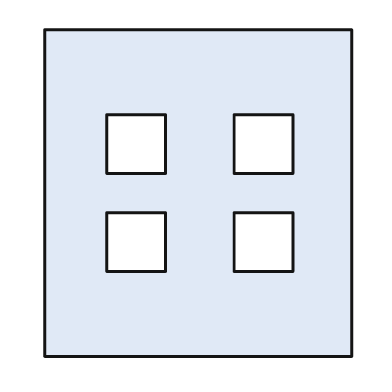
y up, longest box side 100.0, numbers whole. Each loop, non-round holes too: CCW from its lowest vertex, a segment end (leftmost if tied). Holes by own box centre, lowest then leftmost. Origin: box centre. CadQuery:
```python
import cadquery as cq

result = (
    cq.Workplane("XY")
    .moveTo(-47.0, -50.0)
    .lineTo(47.0, -50.0)
    .lineTo(47.0, 50.0)
    .lineTo(-47.0, 50.0)
    .close()
    .moveTo(-28.0, -24.0)
    .lineTo(-10.0, -24.0)
    .lineTo(-10.0, -6.0)
    .lineTo(-28.0, -6.0)
    .close()
    .moveTo(11.0, -24.0)
    .lineTo(29.0, -24.0)
    .lineTo(29.0, -6.0)
    .lineTo(11.0, -6.0)
    .close()
    .moveTo(-28.0, 6.0)
    .lineTo(-10.0, 6.0)
    .lineTo(-10.0, 24.0)
    .lineTo(-28.0, 24.0)
    .close()
    .moveTo(11.0, 6.0)
    .lineTo(29.0, 6.0)
    .lineTo(29.0, 24.0)
    .lineTo(11.0, 24.0)
    .close()
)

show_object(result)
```